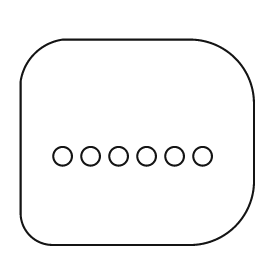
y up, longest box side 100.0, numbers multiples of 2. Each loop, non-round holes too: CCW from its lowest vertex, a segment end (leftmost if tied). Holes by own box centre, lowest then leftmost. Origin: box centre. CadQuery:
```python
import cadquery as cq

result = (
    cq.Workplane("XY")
    .moveTo(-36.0, -44.0)
    .lineTo(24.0, -44.0)
    .threePointArc((42.0, -36.0), (50.0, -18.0))
    .lineTo(50.0, 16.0)
    .threePointArc((42.0, 36.0), (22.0, 44.0))
    .lineTo(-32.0, 44.0)
    .threePointArc((-44.0, 38.0), (-50.0, 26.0))
    .lineTo(-50.0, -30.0)
    .threePointArc((-46.0, -40.0), (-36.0, -44.0))
    .close()
    .moveTo(-32.0, -6.0)
    .circle(4.0)
    .moveTo(-20.0, -6.0)
    .circle(4.0)
    .moveTo(-8.0, -6.0)
    .circle(4.0)
    .moveTo(4.0, -6.0)
    .circle(4.0)
    .moveTo(16.0, -6.0)
    .circle(4.0)
    .moveTo(28.0, -6.0)
    .circle(4.0)
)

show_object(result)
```